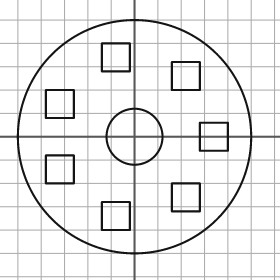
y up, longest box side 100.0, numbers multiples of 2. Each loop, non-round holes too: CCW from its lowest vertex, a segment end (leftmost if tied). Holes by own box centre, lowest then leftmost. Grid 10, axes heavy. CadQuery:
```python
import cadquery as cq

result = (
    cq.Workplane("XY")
    .moveTo(0.0, 0.0)
    .circle(50.0)
    .moveTo(-14.0, -40.0)
    .lineTo(-2.0, -40.0)
    .lineTo(-2.0, -28.0)
    .lineTo(-14.0, -28.0)
    .close()
    .moveTo(16.0, -32.0)
    .lineTo(28.0, -32.0)
    .lineTo(28.0, -20.0)
    .lineTo(16.0, -20.0)
    .close()
    .moveTo(-38.0, -20.0)
    .lineTo(-26.0, -20.0)
    .lineTo(-26.0, -8.0)
    .lineTo(-38.0, -8.0)
    .close()
    .moveTo(0.0, 0.0)
    .circle(12.0)
    .moveTo(28.0, -6.0)
    .lineTo(40.0, -6.0)
    .lineTo(40.0, 6.0)
    .lineTo(28.0, 6.0)
    .close()
    .moveTo(-38.0, 8.0)
    .lineTo(-26.0, 8.0)
    .lineTo(-26.0, 20.0)
    .lineTo(-38.0, 20.0)
    .close()
    .moveTo(16.0, 20.0)
    .lineTo(28.0, 20.0)
    .lineTo(28.0, 32.0)
    .lineTo(16.0, 32.0)
    .close()
    .moveTo(-14.0, 28.0)
    .lineTo(-2.0, 28.0)
    .lineTo(-2.0, 40.0)
    .lineTo(-14.0, 40.0)
    .close()
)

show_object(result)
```